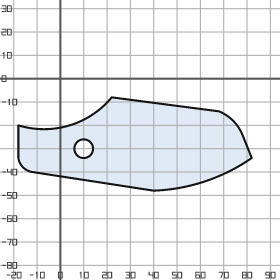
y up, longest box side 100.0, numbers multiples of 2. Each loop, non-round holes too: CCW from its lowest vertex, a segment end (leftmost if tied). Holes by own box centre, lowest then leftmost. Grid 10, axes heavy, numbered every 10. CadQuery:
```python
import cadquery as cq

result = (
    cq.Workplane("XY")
    .moveTo(40.0, -48.0)
    .threePointArc((62.0, -44.0), (82.0, -34.0))
    .lineTo(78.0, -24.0)
    .threePointArc((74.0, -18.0), (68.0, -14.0))
    .lineTo(22.0, -8.0)
    .threePointArc((4.0, -20.0), (-18.0, -20.0))
    .lineTo(-18.0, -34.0)
    .threePointArc((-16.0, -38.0), (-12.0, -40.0))
    .close()
    .moveTo(10.0, -30.0)
    .circle(4.0)
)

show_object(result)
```